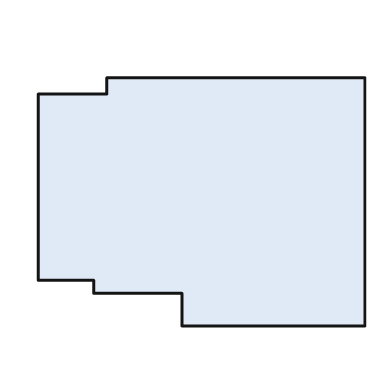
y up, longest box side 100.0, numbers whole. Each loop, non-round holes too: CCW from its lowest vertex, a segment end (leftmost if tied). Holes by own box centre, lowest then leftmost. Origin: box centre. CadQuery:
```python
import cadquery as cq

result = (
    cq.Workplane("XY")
    .moveTo(-6.0, -38.0)
    .lineTo(50.0, -38.0)
    .lineTo(50.0, 38.0)
    .lineTo(-29.0, 38.0)
    .lineTo(-29.0, 33.0)
    .lineTo(-50.0, 33.0)
    .lineTo(-50.0, -24.0)
    .lineTo(-33.0, -24.0)
    .lineTo(-33.0, -28.0)
    .lineTo(-6.0, -28.0)
    .close()
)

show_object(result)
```